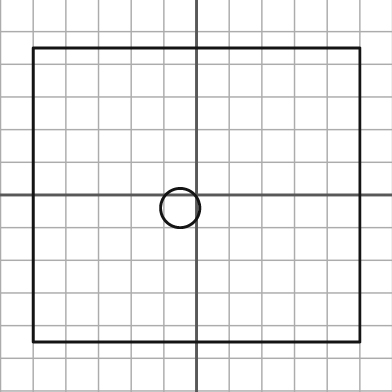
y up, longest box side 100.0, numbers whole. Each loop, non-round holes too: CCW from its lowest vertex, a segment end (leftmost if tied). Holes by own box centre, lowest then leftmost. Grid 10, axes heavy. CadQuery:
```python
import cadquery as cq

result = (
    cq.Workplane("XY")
    .moveTo(-50.0, -45.0)
    .lineTo(50.0, -45.0)
    .lineTo(50.0, 45.0)
    .lineTo(-50.0, 45.0)
    .close()
    .moveTo(-5.0, -4.0)
    .circle(6.0)
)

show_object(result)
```